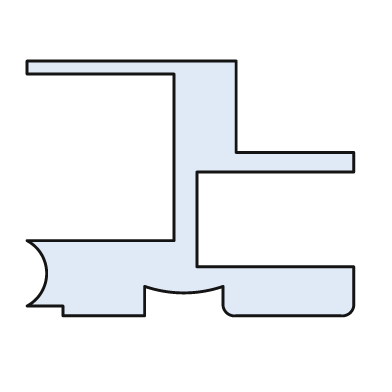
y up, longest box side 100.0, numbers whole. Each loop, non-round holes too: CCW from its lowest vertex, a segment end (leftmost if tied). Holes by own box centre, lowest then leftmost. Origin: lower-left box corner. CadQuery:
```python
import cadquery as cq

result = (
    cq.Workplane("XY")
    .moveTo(11.0, 0.0)
    .lineTo(36.0, 0.0)
    .lineTo(36.0, 9.0)
    .threePointArc((48.0, 7.0), (60.0, 9.0))
    .lineTo(60.0, 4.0)
    .threePointArc((61.0, 1.0), (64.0, 0.0))
    .lineTo(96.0, 0.0)
    .threePointArc((99.0, 1.0), (100.0, 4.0))
    .lineTo(100.0, 15.0)
    .lineTo(52.0, 15.0)
    .lineTo(52.0, 44.0)
    .lineTo(100.0, 44.0)
    .lineTo(100.0, 50.0)
    .lineTo(64.0, 50.0)
    .lineTo(64.0, 78.0)
    .lineTo(0.0, 78.0)
    .lineTo(0.0, 74.0)
    .lineTo(45.0, 74.0)
    .lineTo(45.0, 23.0)
    .lineTo(0.0, 23.0)
    .threePointArc((6.0, 13.0), (0.0, 3.0))
    .lineTo(11.0, 3.0)
    .close()
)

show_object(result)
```